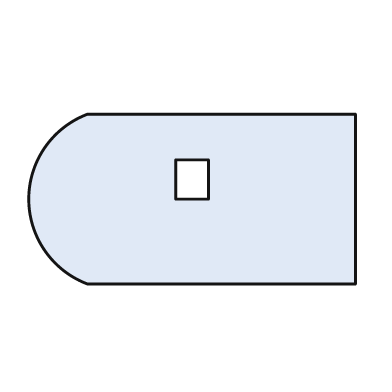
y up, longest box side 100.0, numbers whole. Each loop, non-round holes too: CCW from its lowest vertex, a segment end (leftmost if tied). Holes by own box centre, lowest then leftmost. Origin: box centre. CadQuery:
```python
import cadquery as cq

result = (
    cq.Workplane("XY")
    .moveTo(-32.0, -26.0)
    .lineTo(50.0, -26.0)
    .lineTo(50.0, 26.0)
    .lineTo(-32.0, 26.0)
    .threePointArc((-50.0, 0.0), (-32.0, -26.0))
    .close()
    .moveTo(-5.0, 0.0)
    .lineTo(5.0, 0.0)
    .lineTo(5.0, 12.0)
    .lineTo(-5.0, 12.0)
    .close()
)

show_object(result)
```